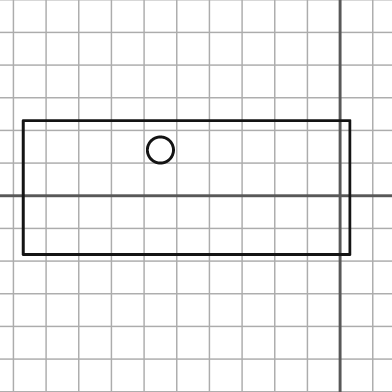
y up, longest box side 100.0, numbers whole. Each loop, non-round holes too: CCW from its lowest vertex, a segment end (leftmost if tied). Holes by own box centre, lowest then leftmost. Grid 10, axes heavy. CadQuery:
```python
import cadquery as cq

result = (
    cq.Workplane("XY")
    .moveTo(-97.0, -18.0)
    .lineTo(3.0, -18.0)
    .lineTo(3.0, 23.0)
    .lineTo(-97.0, 23.0)
    .close()
    .moveTo(-55.0, 14.0)
    .circle(4.0)
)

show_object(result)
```